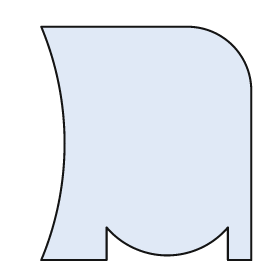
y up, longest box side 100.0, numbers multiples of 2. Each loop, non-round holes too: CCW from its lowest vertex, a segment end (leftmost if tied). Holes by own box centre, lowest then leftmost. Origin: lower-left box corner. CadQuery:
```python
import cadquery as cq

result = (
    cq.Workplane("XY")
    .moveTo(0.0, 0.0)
    .lineTo(28.0, 0.0)
    .lineTo(28.0, 14.0)
    .threePointArc((54.0, 2.0), (80.0, 14.0))
    .lineTo(80.0, 0.0)
    .lineTo(90.0, 0.0)
    .lineTo(90.0, 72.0)
    .threePointArc((82.0, 92.0), (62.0, 100.0))
    .lineTo(0.0, 100.0)
    .threePointArc((10.0, 50.0), (0.0, 0.0))
    .close()
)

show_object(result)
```